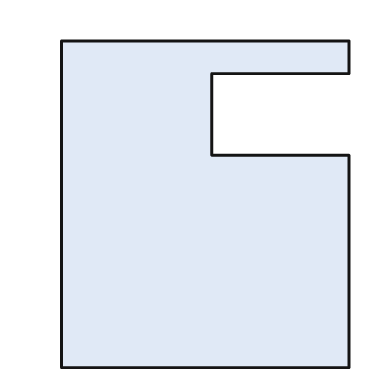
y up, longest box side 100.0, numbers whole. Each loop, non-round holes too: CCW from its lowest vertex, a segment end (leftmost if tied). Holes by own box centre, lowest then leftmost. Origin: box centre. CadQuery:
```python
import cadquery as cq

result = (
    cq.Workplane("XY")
    .moveTo(-44.0, -50.0)
    .lineTo(44.0, -50.0)
    .lineTo(44.0, 15.0)
    .lineTo(2.0, 15.0)
    .lineTo(2.0, 40.0)
    .lineTo(44.0, 40.0)
    .lineTo(44.0, 50.0)
    .lineTo(-44.0, 50.0)
    .close()
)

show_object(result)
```